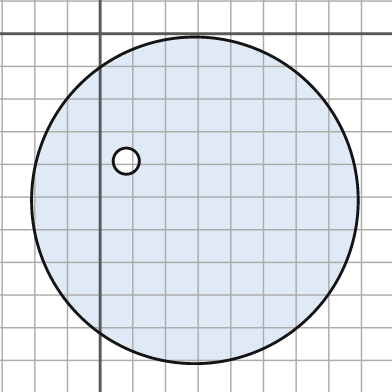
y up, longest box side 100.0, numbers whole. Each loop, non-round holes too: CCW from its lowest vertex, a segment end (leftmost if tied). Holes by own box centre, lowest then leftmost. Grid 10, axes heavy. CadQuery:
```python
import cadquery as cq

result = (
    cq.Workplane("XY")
    .moveTo(29.0, -51.0)
    .circle(50.0)
    .moveTo(8.0, -39.0)
    .circle(4.0)
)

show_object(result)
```